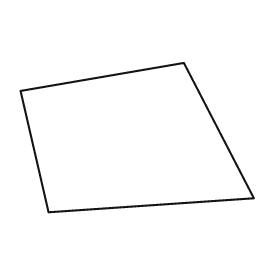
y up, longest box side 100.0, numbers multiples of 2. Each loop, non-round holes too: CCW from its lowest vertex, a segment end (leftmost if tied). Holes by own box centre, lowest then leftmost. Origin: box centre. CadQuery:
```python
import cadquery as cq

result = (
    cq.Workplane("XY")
    .moveTo(-38.0, -32.0)
    .lineTo(50.0, -26.0)
    .lineTo(20.0, 32.0)
    .lineTo(-50.0, 20.0)
    .close()
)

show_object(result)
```